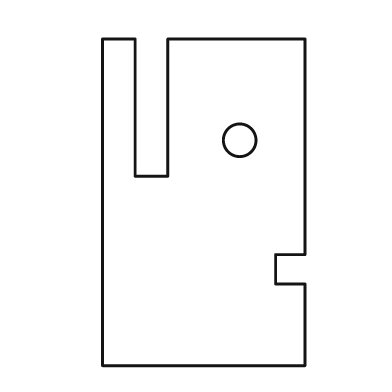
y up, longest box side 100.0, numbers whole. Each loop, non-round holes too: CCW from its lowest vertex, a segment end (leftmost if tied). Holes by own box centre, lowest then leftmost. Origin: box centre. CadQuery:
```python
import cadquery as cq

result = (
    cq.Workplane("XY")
    .moveTo(-31.0, -50.0)
    .lineTo(31.0, -50.0)
    .lineTo(31.0, -25.0)
    .lineTo(22.0, -25.0)
    .lineTo(22.0, -16.0)
    .lineTo(31.0, -16.0)
    .lineTo(31.0, 50.0)
    .lineTo(-11.0, 50.0)
    .lineTo(-11.0, 8.0)
    .lineTo(-21.0, 8.0)
    .lineTo(-21.0, 50.0)
    .lineTo(-31.0, 50.0)
    .close()
    .moveTo(11.0, 19.0)
    .circle(5.0)
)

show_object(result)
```